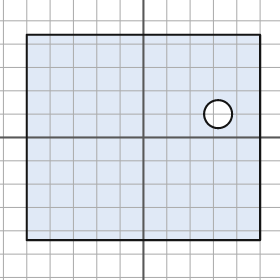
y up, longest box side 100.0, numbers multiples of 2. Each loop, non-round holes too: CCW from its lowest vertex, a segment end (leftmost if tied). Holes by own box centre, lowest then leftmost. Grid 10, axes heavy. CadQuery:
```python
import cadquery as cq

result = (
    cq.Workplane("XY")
    .moveTo(-50.0, -44.0)
    .lineTo(50.0, -44.0)
    .lineTo(50.0, 44.0)
    .lineTo(-50.0, 44.0)
    .close()
    .moveTo(32.0, 10.0)
    .circle(6.0)
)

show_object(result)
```